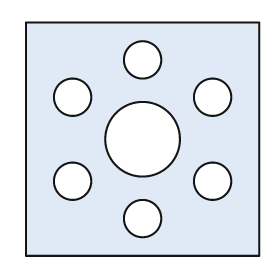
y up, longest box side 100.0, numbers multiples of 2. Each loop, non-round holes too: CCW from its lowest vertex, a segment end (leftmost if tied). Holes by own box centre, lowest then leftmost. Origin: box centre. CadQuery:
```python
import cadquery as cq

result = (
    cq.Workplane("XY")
    .moveTo(-50.0, -50.0)
    .lineTo(50.0, -50.0)
    .lineTo(50.0, 50.0)
    .lineTo(-50.0, 50.0)
    .close()
    .moveTo(0.0, -34.0)
    .circle(8.0)
    .moveTo(-30.0, -18.0)
    .circle(8.0)
    .moveTo(30.0, -18.0)
    .circle(8.0)
    .moveTo(0.0, 0.0)
    .circle(16.0)
    .moveTo(-30.0, 18.0)
    .circle(8.0)
    .moveTo(30.0, 18.0)
    .circle(8.0)
    .moveTo(0.0, 34.0)
    .circle(8.0)
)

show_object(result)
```